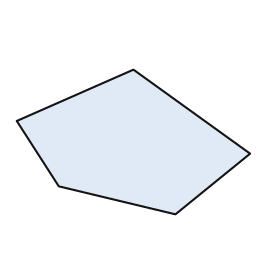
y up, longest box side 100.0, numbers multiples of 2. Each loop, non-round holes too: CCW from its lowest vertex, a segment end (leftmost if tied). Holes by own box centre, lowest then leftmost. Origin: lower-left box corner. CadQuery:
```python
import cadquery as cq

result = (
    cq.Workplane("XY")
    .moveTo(68.0, 0.0)
    .lineTo(100.0, 26.0)
    .lineTo(50.0, 62.0)
    .lineTo(0.0, 40.0)
    .lineTo(18.0, 12.0)
    .close()
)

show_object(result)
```